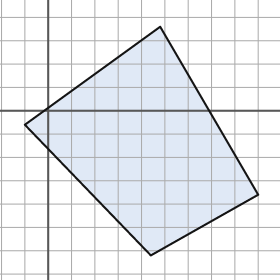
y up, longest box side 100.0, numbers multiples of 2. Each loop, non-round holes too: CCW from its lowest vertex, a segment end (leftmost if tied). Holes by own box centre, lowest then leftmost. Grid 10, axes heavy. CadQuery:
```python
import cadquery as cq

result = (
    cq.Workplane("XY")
    .moveTo(44.0, -62.0)
    .lineTo(90.0, -36.0)
    .lineTo(48.0, 36.0)
    .lineTo(-10.0, -6.0)
    .close()
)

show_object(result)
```